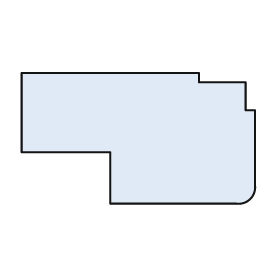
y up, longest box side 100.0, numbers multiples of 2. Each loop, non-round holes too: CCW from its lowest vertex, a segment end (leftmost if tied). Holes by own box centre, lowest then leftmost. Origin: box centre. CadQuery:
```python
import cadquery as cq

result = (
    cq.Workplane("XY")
    .moveTo(-12.0, -28.0)
    .lineTo(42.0, -28.0)
    .threePointArc((48.0, -26.0), (50.0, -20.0))
    .lineTo(50.0, 12.0)
    .lineTo(46.0, 12.0)
    .lineTo(46.0, 24.0)
    .lineTo(26.0, 24.0)
    .lineTo(26.0, 28.0)
    .lineTo(-50.0, 28.0)
    .lineTo(-50.0, -6.0)
    .lineTo(-12.0, -6.0)
    .close()
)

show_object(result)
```